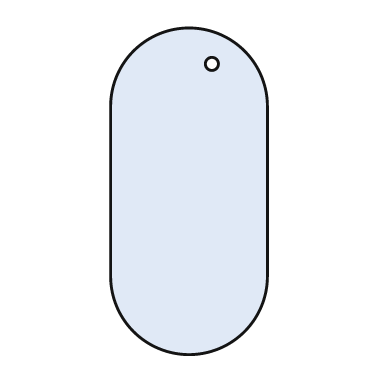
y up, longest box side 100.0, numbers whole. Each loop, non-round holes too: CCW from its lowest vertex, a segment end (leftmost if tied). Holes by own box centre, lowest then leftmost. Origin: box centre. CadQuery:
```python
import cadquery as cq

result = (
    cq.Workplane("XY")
    .moveTo(-24.0, -26.0)
    .threePointArc((0.0, -50.0), (24.0, -26.0))
    .lineTo(24.0, 26.0)
    .threePointArc((0.0, 50.0), (-24.0, 26.0))
    .close()
    .moveTo(7.0, 39.0)
    .circle(2.0)
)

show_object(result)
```